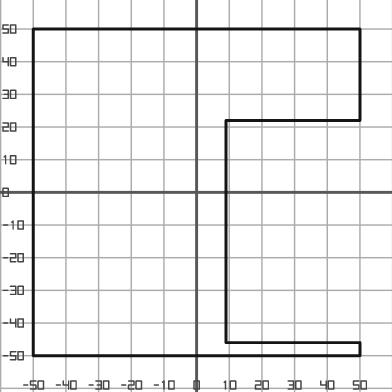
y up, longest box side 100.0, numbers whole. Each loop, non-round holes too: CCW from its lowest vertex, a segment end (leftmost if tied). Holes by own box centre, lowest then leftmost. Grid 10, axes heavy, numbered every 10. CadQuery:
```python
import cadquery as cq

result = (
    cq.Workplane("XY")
    .moveTo(-50.0, -50.0)
    .lineTo(50.0, -50.0)
    .lineTo(50.0, -46.0)
    .lineTo(9.0, -46.0)
    .lineTo(9.0, 22.0)
    .lineTo(50.0, 22.0)
    .lineTo(50.0, 50.0)
    .lineTo(-50.0, 50.0)
    .close()
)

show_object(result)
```